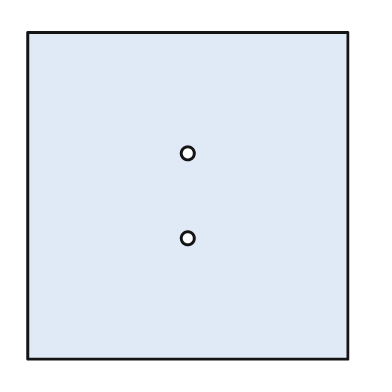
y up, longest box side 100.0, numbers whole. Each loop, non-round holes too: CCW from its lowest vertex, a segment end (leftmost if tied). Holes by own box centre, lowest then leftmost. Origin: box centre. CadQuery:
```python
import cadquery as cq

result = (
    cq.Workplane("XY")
    .moveTo(-49.0, -50.0)
    .lineTo(49.0, -50.0)
    .lineTo(49.0, 50.0)
    .lineTo(-49.0, 50.0)
    .close()
    .moveTo(0.0, -13.0)
    .circle(2.0)
    .moveTo(0.0, 13.0)
    .circle(2.0)
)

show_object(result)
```